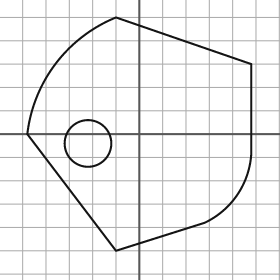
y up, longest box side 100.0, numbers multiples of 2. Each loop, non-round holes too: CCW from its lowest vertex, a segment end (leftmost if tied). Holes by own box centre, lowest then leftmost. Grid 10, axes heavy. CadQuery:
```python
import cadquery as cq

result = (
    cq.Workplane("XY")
    .moveTo(-10.0, -50.0)
    .lineTo(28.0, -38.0)
    .threePointArc((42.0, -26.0), (48.0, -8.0))
    .lineTo(48.0, 30.0)
    .lineTo(-10.0, 50.0)
    .threePointArc((-36.0, 30.0), (-48.0, 0.0))
    .close()
    .moveTo(-22.0, -4.0)
    .circle(10.0)
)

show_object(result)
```